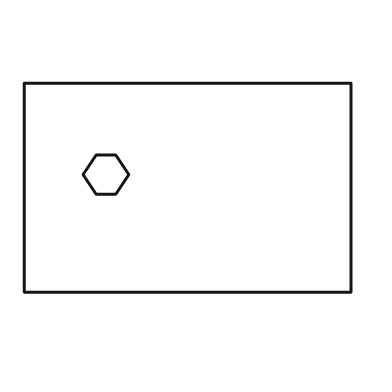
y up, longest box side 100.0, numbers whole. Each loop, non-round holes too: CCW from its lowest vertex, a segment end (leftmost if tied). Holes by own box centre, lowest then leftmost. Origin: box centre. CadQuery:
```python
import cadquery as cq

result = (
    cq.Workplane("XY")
    .moveTo(-50.0, -32.0)
    .lineTo(50.0, -32.0)
    .lineTo(50.0, 32.0)
    .lineTo(-50.0, 32.0)
    .close()
    .moveTo(-28.0, -2.0)
    .lineTo(-22.0, -2.0)
    .lineTo(-18.0, 4.0)
    .lineTo(-22.0, 10.0)
    .lineTo(-28.0, 10.0)
    .lineTo(-32.0, 4.0)
    .close()
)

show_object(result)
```